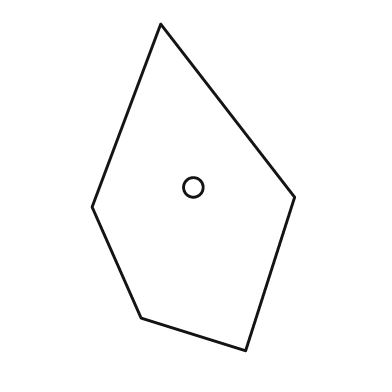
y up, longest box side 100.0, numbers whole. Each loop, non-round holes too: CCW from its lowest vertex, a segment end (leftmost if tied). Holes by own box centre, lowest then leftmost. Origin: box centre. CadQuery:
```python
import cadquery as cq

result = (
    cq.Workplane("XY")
    .moveTo(16.0, -50.0)
    .lineTo(31.0, -3.0)
    .lineTo(-10.0, 50.0)
    .lineTo(-31.0, -6.0)
    .lineTo(-16.0, -40.0)
    .close()
    .moveTo(0.0, 0.0)
    .circle(3.0)
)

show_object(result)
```